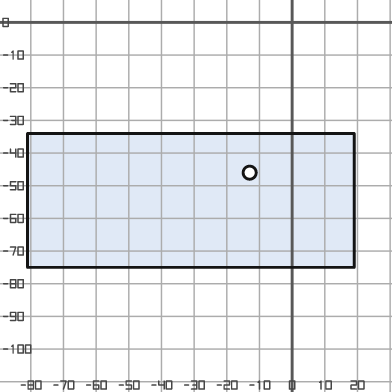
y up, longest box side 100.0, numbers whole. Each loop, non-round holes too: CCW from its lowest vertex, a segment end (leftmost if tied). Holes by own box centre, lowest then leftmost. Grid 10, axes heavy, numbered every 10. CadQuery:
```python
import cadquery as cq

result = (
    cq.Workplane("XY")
    .moveTo(-81.0, -75.0)
    .lineTo(19.0, -75.0)
    .lineTo(19.0, -34.0)
    .lineTo(-81.0, -34.0)
    .close()
    .moveTo(-13.0, -46.0)
    .circle(2.0)
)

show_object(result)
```